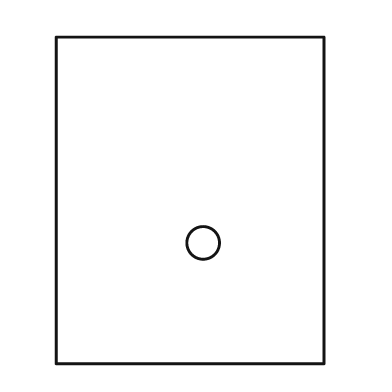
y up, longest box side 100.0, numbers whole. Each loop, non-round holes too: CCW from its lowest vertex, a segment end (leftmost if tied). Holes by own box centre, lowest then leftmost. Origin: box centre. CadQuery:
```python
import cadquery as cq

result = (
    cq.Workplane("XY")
    .moveTo(-41.0, -50.0)
    .lineTo(41.0, -50.0)
    .lineTo(41.0, 50.0)
    .lineTo(-41.0, 50.0)
    .close()
    .moveTo(4.0, -13.0)
    .circle(5.0)
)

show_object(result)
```